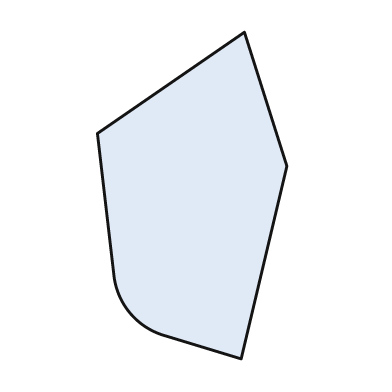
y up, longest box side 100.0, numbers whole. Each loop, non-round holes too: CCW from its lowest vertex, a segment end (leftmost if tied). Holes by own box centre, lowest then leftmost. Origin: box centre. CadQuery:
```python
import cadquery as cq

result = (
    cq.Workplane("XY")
    .moveTo(15.0, -50.0)
    .lineTo(29.0, 9.0)
    .lineTo(16.0, 50.0)
    .lineTo(-29.0, 19.0)
    .lineTo(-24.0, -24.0)
    .threePointArc((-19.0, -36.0), (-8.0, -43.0))
    .close()
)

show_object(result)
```